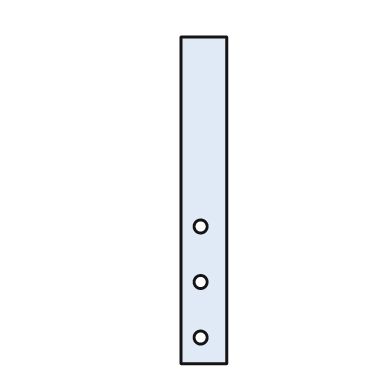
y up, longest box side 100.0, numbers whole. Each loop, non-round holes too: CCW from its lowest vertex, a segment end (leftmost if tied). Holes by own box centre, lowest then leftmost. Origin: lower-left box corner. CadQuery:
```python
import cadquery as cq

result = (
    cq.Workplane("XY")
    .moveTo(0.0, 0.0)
    .lineTo(14.0, 0.0)
    .lineTo(14.0, 100.0)
    .lineTo(0.0, 100.0)
    .close()
    .moveTo(6.0, 8.0)
    .circle(2.0)
    .moveTo(6.0, 25.0)
    .circle(2.0)
    .moveTo(6.0, 42.0)
    .circle(2.0)
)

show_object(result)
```